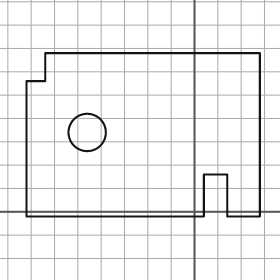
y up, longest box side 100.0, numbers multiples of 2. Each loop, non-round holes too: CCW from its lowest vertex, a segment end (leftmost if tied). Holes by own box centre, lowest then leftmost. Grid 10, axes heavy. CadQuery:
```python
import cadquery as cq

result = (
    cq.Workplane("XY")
    .moveTo(-72.0, -2.0)
    .lineTo(4.0, -2.0)
    .lineTo(4.0, 16.0)
    .lineTo(14.0, 16.0)
    .lineTo(14.0, -2.0)
    .lineTo(28.0, -2.0)
    .lineTo(28.0, 68.0)
    .lineTo(-64.0, 68.0)
    .lineTo(-64.0, 56.0)
    .lineTo(-72.0, 56.0)
    .close()
    .moveTo(-46.0, 34.0)
    .circle(8.0)
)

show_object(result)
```